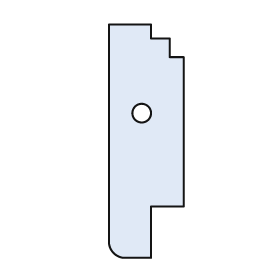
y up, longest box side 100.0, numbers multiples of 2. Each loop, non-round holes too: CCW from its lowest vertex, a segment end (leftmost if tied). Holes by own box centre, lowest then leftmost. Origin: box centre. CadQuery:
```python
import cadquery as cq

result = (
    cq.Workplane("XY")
    .moveTo(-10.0, -50.0)
    .lineTo(2.0, -50.0)
    .lineTo(2.0, -28.0)
    .lineTo(16.0, -28.0)
    .lineTo(16.0, 36.0)
    .lineTo(10.0, 36.0)
    .lineTo(10.0, 44.0)
    .lineTo(2.0, 44.0)
    .lineTo(2.0, 50.0)
    .lineTo(-16.0, 50.0)
    .lineTo(-16.0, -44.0)
    .threePointArc((-14.0, -48.0), (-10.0, -50.0))
    .close()
    .moveTo(-2.0, 12.0)
    .circle(4.0)
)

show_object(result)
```